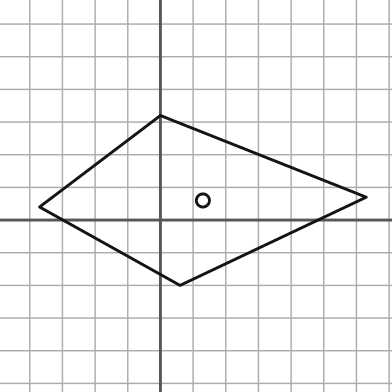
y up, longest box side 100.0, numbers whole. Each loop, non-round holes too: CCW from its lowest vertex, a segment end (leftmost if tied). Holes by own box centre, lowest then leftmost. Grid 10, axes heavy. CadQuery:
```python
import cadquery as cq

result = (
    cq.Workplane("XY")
    .moveTo(6.0, -20.0)
    .lineTo(63.0, 7.0)
    .lineTo(0.0, 32.0)
    .lineTo(-37.0, 4.0)
    .close()
    .moveTo(13.0, 6.0)
    .circle(2.0)
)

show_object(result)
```